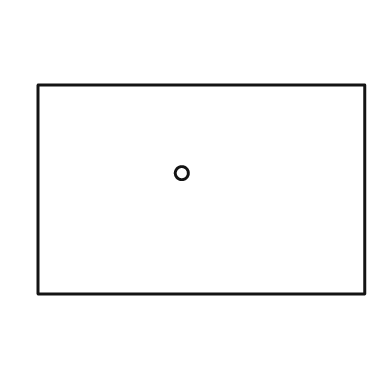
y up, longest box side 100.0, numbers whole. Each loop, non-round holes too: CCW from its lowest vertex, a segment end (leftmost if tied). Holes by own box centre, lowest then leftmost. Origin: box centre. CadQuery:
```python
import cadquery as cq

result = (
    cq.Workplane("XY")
    .moveTo(-50.0, -32.0)
    .lineTo(50.0, -32.0)
    .lineTo(50.0, 32.0)
    .lineTo(-50.0, 32.0)
    .close()
    .moveTo(-6.0, 5.0)
    .circle(2.0)
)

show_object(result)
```